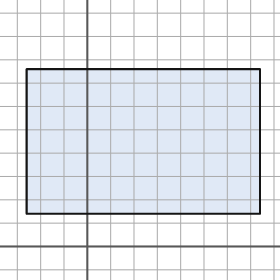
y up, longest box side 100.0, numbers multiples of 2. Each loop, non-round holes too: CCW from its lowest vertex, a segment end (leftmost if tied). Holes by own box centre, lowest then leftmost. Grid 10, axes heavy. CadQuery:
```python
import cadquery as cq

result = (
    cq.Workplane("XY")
    .moveTo(-26.0, 14.0)
    .lineTo(74.0, 14.0)
    .lineTo(74.0, 76.0)
    .lineTo(-26.0, 76.0)
    .close()
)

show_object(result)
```